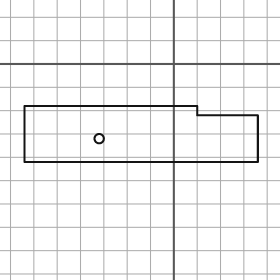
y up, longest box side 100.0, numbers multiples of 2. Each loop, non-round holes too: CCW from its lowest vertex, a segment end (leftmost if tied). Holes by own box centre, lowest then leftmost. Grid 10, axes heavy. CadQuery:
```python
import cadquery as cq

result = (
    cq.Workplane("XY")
    .moveTo(-64.0, -42.0)
    .lineTo(36.0, -42.0)
    .lineTo(36.0, -22.0)
    .lineTo(10.0, -22.0)
    .lineTo(10.0, -18.0)
    .lineTo(-64.0, -18.0)
    .close()
    .moveTo(-32.0, -32.0)
    .circle(2.0)
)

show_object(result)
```